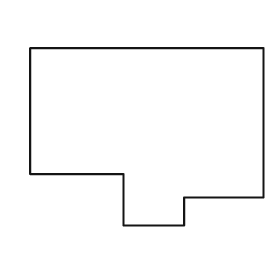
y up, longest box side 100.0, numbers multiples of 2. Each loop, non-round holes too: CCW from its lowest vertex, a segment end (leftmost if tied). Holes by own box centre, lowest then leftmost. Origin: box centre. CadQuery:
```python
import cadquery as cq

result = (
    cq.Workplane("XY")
    .moveTo(-10.0, -38.0)
    .lineTo(16.0, -38.0)
    .lineTo(16.0, -26.0)
    .lineTo(50.0, -26.0)
    .lineTo(50.0, 38.0)
    .lineTo(-50.0, 38.0)
    .lineTo(-50.0, -16.0)
    .lineTo(-10.0, -16.0)
    .close()
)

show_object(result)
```